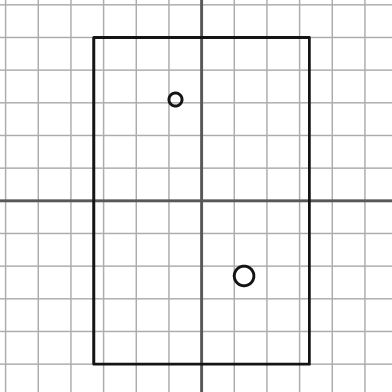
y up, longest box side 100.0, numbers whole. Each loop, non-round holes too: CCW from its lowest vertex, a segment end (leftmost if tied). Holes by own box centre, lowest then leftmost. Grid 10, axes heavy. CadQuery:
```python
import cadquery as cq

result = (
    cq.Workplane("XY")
    .moveTo(-33.0, -50.0)
    .lineTo(33.0, -50.0)
    .lineTo(33.0, 50.0)
    .lineTo(-33.0, 50.0)
    .close()
    .moveTo(13.0, -23.0)
    .circle(3.0)
    .moveTo(-8.0, 31.0)
    .circle(2.0)
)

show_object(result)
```